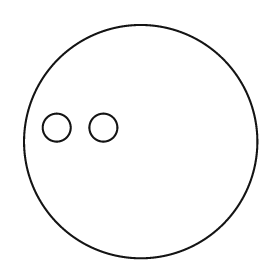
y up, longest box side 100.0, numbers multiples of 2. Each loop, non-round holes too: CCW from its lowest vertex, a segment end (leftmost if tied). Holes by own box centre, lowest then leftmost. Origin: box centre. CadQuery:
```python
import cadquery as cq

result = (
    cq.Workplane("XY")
    .moveTo(0.0, 0.0)
    .circle(50.0)
    .moveTo(-36.0, 6.0)
    .circle(6.0)
    .moveTo(-16.0, 6.0)
    .circle(6.0)
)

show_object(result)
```